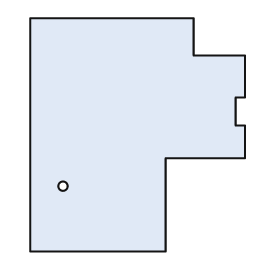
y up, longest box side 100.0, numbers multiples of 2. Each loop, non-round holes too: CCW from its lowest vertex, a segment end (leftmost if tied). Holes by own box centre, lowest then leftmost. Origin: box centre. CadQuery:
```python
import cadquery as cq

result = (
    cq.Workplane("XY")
    .moveTo(-46.0, -50.0)
    .lineTo(12.0, -50.0)
    .lineTo(12.0, -10.0)
    .lineTo(46.0, -10.0)
    .lineTo(46.0, 4.0)
    .lineTo(42.0, 4.0)
    .lineTo(42.0, 16.0)
    .lineTo(46.0, 16.0)
    .lineTo(46.0, 34.0)
    .lineTo(24.0, 34.0)
    .lineTo(24.0, 50.0)
    .lineTo(-46.0, 50.0)
    .close()
    .moveTo(-32.0, -22.0)
    .circle(2.0)
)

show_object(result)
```